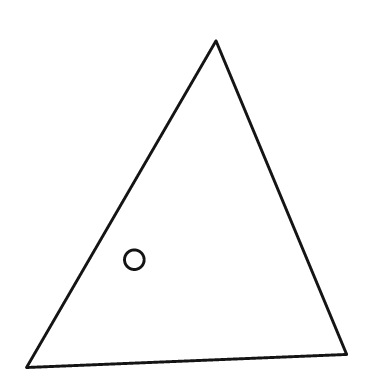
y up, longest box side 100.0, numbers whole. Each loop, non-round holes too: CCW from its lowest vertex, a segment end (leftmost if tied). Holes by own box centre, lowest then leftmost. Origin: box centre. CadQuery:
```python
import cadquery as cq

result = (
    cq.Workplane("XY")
    .moveTo(-49.0, -50.0)
    .lineTo(49.0, -46.0)
    .lineTo(9.0, 50.0)
    .close()
    .moveTo(-16.0, -17.0)
    .circle(3.0)
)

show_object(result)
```